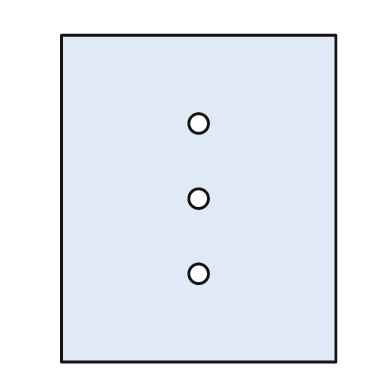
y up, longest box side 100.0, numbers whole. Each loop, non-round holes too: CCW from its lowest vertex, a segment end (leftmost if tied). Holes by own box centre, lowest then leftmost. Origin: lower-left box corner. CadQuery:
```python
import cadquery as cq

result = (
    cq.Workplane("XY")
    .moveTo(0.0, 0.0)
    .lineTo(84.0, 0.0)
    .lineTo(84.0, 100.0)
    .lineTo(0.0, 100.0)
    .close()
    .moveTo(42.0, 27.0)
    .circle(3.0)
    .moveTo(42.0, 50.0)
    .circle(3.0)
    .moveTo(42.0, 73.0)
    .circle(3.0)
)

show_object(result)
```